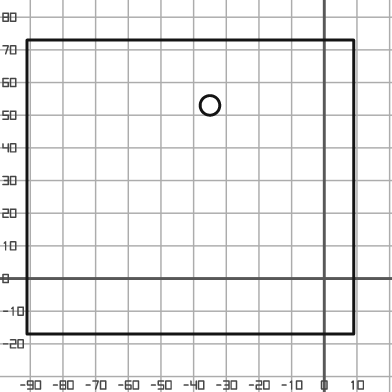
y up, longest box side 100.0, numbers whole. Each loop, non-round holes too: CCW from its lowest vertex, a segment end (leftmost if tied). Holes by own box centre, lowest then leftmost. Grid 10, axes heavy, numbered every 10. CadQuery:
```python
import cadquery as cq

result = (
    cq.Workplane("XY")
    .moveTo(-91.0, -17.0)
    .lineTo(9.0, -17.0)
    .lineTo(9.0, 73.0)
    .lineTo(-91.0, 73.0)
    .close()
    .moveTo(-35.0, 53.0)
    .circle(3.0)
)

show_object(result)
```